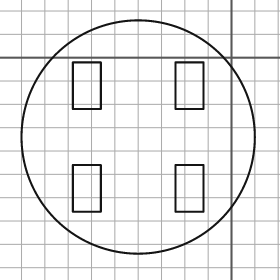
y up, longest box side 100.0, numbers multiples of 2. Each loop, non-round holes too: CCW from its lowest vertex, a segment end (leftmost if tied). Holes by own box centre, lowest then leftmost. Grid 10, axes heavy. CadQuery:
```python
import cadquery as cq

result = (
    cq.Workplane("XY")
    .moveTo(-40.0, -34.0)
    .circle(50.0)
    .moveTo(-68.0, -66.0)
    .lineTo(-56.0, -66.0)
    .lineTo(-56.0, -46.0)
    .lineTo(-68.0, -46.0)
    .close()
    .moveTo(-24.0, -66.0)
    .lineTo(-12.0, -66.0)
    .lineTo(-12.0, -46.0)
    .lineTo(-24.0, -46.0)
    .close()
    .moveTo(-68.0, -22.0)
    .lineTo(-56.0, -22.0)
    .lineTo(-56.0, -2.0)
    .lineTo(-68.0, -2.0)
    .close()
    .moveTo(-24.0, -22.0)
    .lineTo(-12.0, -22.0)
    .lineTo(-12.0, -2.0)
    .lineTo(-24.0, -2.0)
    .close()
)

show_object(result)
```